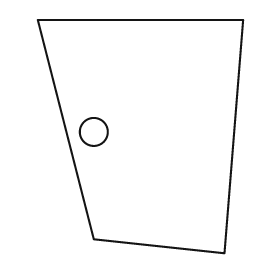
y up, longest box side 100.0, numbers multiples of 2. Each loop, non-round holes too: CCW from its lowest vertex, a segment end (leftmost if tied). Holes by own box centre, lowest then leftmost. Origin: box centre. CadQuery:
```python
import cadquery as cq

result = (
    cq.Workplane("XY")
    .moveTo(36.0, -50.0)
    .lineTo(44.0, 50.0)
    .lineTo(-44.0, 50.0)
    .lineTo(-20.0, -44.0)
    .close()
    .moveTo(-20.0, 2.0)
    .circle(6.0)
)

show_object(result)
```